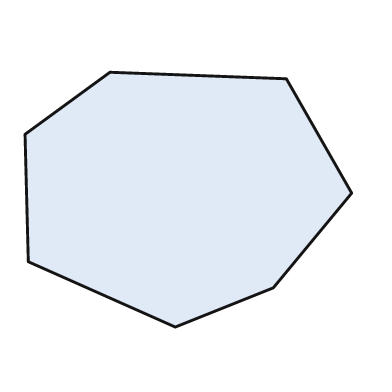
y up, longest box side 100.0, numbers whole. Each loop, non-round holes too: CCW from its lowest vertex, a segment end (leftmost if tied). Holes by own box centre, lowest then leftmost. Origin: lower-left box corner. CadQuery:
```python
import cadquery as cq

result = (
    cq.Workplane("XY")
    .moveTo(46.0, 0.0)
    .lineTo(76.0, 12.0)
    .lineTo(100.0, 41.0)
    .lineTo(80.0, 76.0)
    .lineTo(26.0, 78.0)
    .lineTo(0.0, 59.0)
    .lineTo(1.0, 20.0)
    .close()
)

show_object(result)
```